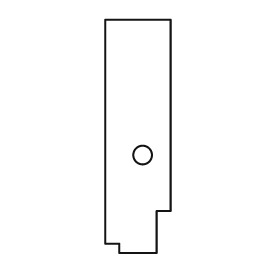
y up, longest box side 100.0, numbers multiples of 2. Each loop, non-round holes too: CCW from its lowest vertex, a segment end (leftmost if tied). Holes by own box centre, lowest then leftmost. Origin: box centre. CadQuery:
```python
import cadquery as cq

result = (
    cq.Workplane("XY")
    .moveTo(-8.0, -50.0)
    .lineTo(8.0, -50.0)
    .lineTo(8.0, -32.0)
    .lineTo(14.0, -32.0)
    .lineTo(14.0, 50.0)
    .lineTo(-14.0, 50.0)
    .lineTo(-14.0, -46.0)
    .lineTo(-8.0, -46.0)
    .close()
    .moveTo(2.0, -8.0)
    .circle(4.0)
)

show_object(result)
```